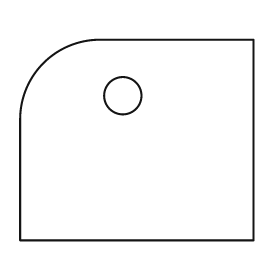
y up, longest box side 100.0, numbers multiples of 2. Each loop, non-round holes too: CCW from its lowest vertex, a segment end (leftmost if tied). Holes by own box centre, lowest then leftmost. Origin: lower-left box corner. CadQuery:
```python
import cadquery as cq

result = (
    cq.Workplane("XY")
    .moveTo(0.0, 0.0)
    .lineTo(100.0, 0.0)
    .lineTo(100.0, 86.0)
    .lineTo(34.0, 86.0)
    .threePointArc((10.0, 76.0), (0.0, 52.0))
    .close()
    .moveTo(44.0, 62.0)
    .circle(8.0)
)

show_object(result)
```